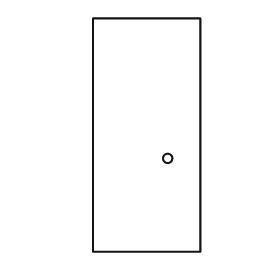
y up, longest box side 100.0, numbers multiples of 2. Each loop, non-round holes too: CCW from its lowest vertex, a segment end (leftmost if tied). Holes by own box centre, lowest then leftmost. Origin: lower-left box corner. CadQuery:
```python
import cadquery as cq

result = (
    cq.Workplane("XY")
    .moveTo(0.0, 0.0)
    .lineTo(46.0, 0.0)
    .lineTo(46.0, 100.0)
    .lineTo(0.0, 100.0)
    .close()
    .moveTo(32.0, 40.0)
    .circle(2.0)
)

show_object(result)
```